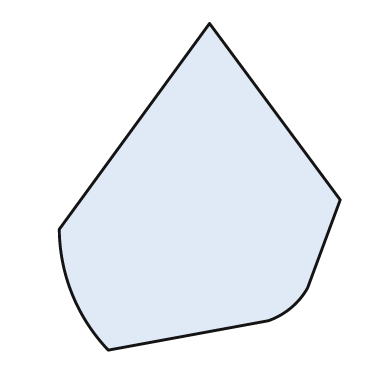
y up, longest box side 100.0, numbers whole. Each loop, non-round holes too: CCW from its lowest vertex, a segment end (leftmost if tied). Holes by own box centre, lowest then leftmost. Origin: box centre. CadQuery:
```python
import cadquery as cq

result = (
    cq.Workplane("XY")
    .moveTo(-28.0, -50.0)
    .lineTo(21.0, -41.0)
    .threePointArc((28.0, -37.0), (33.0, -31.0))
    .lineTo(43.0, -4.0)
    .lineTo(3.0, 50.0)
    .lineTo(-43.0, -13.0)
    .threePointArc((-39.0, -33.0), (-28.0, -50.0))
    .close()
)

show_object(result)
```